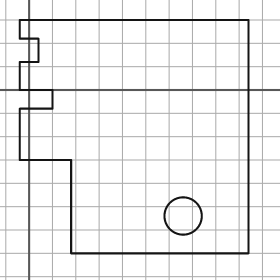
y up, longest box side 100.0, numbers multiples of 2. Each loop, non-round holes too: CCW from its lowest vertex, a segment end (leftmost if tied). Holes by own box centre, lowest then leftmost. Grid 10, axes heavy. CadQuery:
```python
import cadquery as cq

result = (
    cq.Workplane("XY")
    .moveTo(18.0, -70.0)
    .lineTo(94.0, -70.0)
    .lineTo(94.0, 30.0)
    .lineTo(-4.0, 30.0)
    .lineTo(-4.0, 22.0)
    .lineTo(4.0, 22.0)
    .lineTo(4.0, 12.0)
    .lineTo(-4.0, 12.0)
    .lineTo(-4.0, 0.0)
    .lineTo(10.0, 0.0)
    .lineTo(10.0, -8.0)
    .lineTo(-4.0, -8.0)
    .lineTo(-4.0, -30.0)
    .lineTo(18.0, -30.0)
    .close()
    .moveTo(66.0, -54.0)
    .circle(8.0)
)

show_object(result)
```